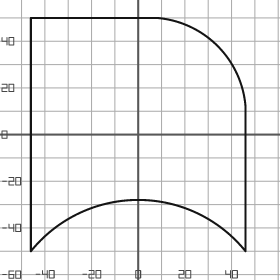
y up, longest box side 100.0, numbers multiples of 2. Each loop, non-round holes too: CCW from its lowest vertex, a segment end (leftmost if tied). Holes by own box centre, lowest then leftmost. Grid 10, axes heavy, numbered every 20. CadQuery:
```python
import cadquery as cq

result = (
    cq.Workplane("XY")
    .moveTo(-46.0, -50.0)
    .threePointArc((0.0, -28.0), (46.0, -50.0))
    .lineTo(46.0, 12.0)
    .threePointArc((34.0, 38.0), (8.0, 50.0))
    .lineTo(-46.0, 50.0)
    .close()
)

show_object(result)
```